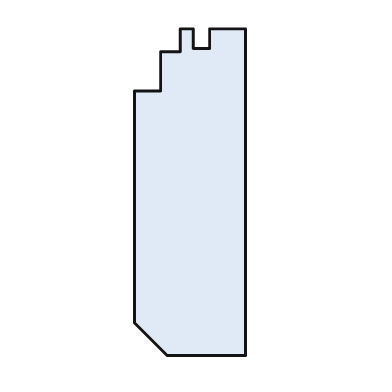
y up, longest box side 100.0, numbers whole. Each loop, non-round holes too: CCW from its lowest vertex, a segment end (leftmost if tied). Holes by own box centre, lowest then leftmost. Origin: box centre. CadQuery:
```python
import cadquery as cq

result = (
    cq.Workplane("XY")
    .moveTo(-7.0, -50.0)
    .lineTo(17.0, -50.0)
    .lineTo(17.0, 50.0)
    .lineTo(6.0, 50.0)
    .lineTo(6.0, 44.0)
    .lineTo(1.0, 44.0)
    .lineTo(1.0, 50.0)
    .lineTo(-3.0, 50.0)
    .lineTo(-3.0, 43.0)
    .lineTo(-9.0, 43.0)
    .lineTo(-9.0, 31.0)
    .lineTo(-17.0, 31.0)
    .lineTo(-17.0, -40.0)
    .close()
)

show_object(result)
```